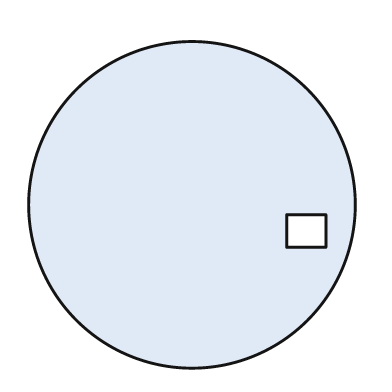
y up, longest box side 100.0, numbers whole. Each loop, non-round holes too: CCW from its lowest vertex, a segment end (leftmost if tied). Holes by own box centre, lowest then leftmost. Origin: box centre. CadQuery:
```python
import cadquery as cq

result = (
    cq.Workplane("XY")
    .moveTo(0.0, 0.0)
    .circle(50.0)
    .moveTo(29.0, -13.0)
    .lineTo(41.0, -13.0)
    .lineTo(41.0, -3.0)
    .lineTo(29.0, -3.0)
    .close()
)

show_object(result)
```